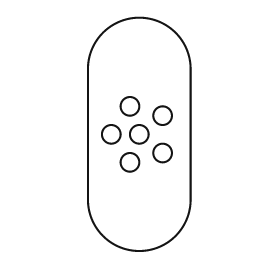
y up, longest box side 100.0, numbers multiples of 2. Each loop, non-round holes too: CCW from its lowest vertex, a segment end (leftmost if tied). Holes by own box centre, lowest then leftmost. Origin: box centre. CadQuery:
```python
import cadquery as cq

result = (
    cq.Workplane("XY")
    .moveTo(-22.0, -28.0)
    .threePointArc((0.0, -50.0), (22.0, -28.0))
    .lineTo(22.0, 28.0)
    .threePointArc((0.0, 50.0), (-22.0, 28.0))
    .close()
    .moveTo(-4.0, -12.0)
    .circle(4.0)
    .moveTo(10.0, -8.0)
    .circle(4.0)
    .moveTo(-12.0, 0.0)
    .circle(4.0)
    .moveTo(0.0, 0.0)
    .circle(4.0)
    .moveTo(10.0, 8.0)
    .circle(4.0)
    .moveTo(-4.0, 12.0)
    .circle(4.0)
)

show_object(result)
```